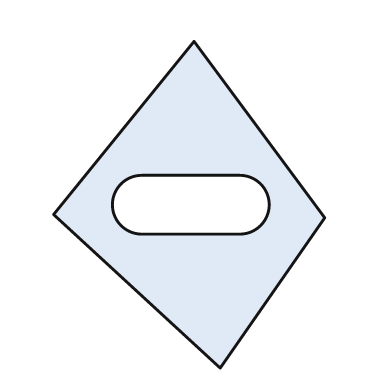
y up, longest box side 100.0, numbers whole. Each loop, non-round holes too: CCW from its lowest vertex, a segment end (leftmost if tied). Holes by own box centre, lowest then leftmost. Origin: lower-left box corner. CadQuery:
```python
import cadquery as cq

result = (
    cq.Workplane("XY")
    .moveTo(51.0, 0.0)
    .lineTo(83.0, 46.0)
    .lineTo(43.0, 100.0)
    .lineTo(0.0, 47.0)
    .close()
    .moveTo(27.0, 41.0)
    .lineTo(57.0, 41.0)
    .threePointArc((66.0, 50.0), (57.0, 59.0))
    .lineTo(27.0, 59.0)
    .threePointArc((18.0, 50.0), (27.0, 41.0))
    .close()
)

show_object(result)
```